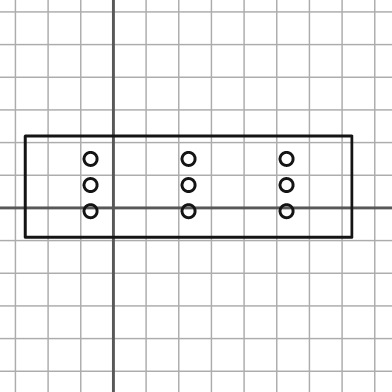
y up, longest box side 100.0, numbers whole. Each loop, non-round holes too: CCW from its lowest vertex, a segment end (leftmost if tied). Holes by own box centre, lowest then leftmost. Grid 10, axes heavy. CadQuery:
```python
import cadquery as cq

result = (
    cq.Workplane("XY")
    .moveTo(-27.0, -9.0)
    .lineTo(73.0, -9.0)
    .lineTo(73.0, 22.0)
    .lineTo(-27.0, 22.0)
    .close()
    .moveTo(-7.0, -1.0)
    .circle(2.0)
    .moveTo(23.0, -1.0)
    .circle(2.0)
    .moveTo(53.0, -1.0)
    .circle(2.0)
    .moveTo(-7.0, 7.0)
    .circle(2.0)
    .moveTo(23.0, 7.0)
    .circle(2.0)
    .moveTo(53.0, 7.0)
    .circle(2.0)
    .moveTo(-7.0, 15.0)
    .circle(2.0)
    .moveTo(23.0, 15.0)
    .circle(2.0)
    .moveTo(53.0, 15.0)
    .circle(2.0)
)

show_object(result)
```